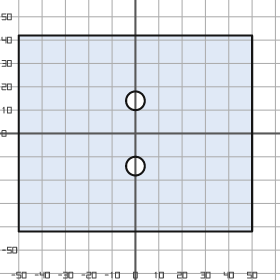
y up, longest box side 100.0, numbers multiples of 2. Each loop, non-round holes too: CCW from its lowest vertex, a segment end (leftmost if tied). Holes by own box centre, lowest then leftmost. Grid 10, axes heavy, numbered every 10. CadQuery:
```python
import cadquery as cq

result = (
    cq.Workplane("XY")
    .moveTo(-50.0, -42.0)
    .lineTo(50.0, -42.0)
    .lineTo(50.0, 42.0)
    .lineTo(-50.0, 42.0)
    .close()
    .moveTo(0.0, -14.0)
    .circle(4.0)
    .moveTo(0.0, 14.0)
    .circle(4.0)
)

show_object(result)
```